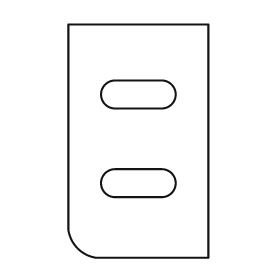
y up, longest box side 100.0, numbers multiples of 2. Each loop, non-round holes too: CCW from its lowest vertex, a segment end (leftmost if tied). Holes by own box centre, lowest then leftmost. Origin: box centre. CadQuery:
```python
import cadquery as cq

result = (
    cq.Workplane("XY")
    .moveTo(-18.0, -50.0)
    .lineTo(30.0, -50.0)
    .lineTo(30.0, 50.0)
    .lineTo(-30.0, 50.0)
    .lineTo(-30.0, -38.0)
    .threePointArc((-26.0, -46.0), (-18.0, -50.0))
    .close()
    .moveTo(-10.0, -24.0)
    .lineTo(10.0, -24.0)
    .threePointArc((16.0, -18.0), (10.0, -12.0))
    .lineTo(-10.0, -12.0)
    .threePointArc((-16.0, -18.0), (-10.0, -24.0))
    .close()
    .moveTo(-10.0, 14.0)
    .lineTo(10.0, 14.0)
    .threePointArc((16.0, 20.0), (10.0, 26.0))
    .lineTo(-10.0, 26.0)
    .threePointArc((-16.0, 20.0), (-10.0, 14.0))
    .close()
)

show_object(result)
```